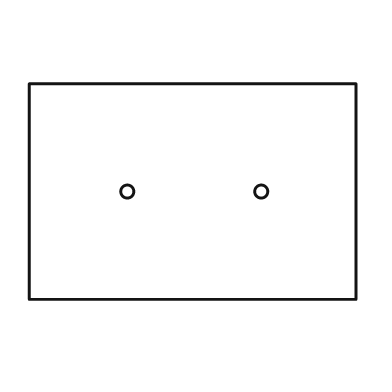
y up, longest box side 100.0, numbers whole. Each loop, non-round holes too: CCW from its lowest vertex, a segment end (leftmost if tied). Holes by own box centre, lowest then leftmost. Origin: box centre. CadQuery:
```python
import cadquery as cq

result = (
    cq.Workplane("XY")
    .moveTo(-50.0, -33.0)
    .lineTo(50.0, -33.0)
    .lineTo(50.0, 33.0)
    .lineTo(-50.0, 33.0)
    .close()
    .moveTo(-20.0, 0.0)
    .circle(2.0)
    .moveTo(21.0, 0.0)
    .circle(2.0)
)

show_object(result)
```